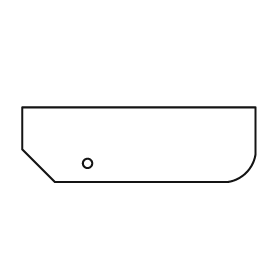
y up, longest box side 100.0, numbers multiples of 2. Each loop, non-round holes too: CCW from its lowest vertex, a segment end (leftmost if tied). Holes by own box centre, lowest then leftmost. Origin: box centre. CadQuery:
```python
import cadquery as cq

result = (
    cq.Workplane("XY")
    .moveTo(-36.0, -16.0)
    .lineTo(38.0, -16.0)
    .threePointArc((46.0, -12.0), (50.0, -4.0))
    .lineTo(50.0, 16.0)
    .lineTo(-50.0, 16.0)
    .lineTo(-50.0, -2.0)
    .close()
    .moveTo(-22.0, -8.0)
    .circle(2.0)
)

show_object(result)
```